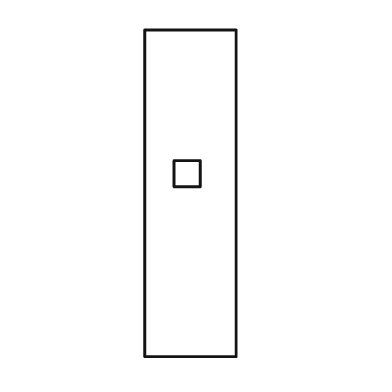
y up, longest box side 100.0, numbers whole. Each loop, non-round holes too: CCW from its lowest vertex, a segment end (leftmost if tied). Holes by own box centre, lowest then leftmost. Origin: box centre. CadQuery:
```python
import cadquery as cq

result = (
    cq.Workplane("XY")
    .moveTo(-14.0, -50.0)
    .lineTo(14.0, -50.0)
    .lineTo(14.0, 50.0)
    .lineTo(-14.0, 50.0)
    .close()
    .moveTo(-5.0, 2.0)
    .lineTo(3.0, 2.0)
    .lineTo(3.0, 10.0)
    .lineTo(-5.0, 10.0)
    .close()
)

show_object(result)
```